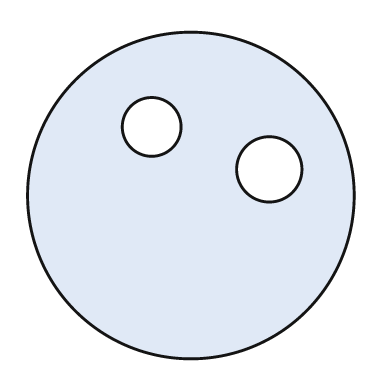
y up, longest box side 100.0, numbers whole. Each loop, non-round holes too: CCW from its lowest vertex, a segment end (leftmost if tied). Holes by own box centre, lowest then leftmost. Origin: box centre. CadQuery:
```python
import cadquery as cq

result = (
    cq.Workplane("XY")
    .moveTo(0.0, 0.0)
    .circle(50.0)
    .moveTo(24.0, 8.0)
    .circle(10.0)
    .moveTo(-12.0, 21.0)
    .circle(9.0)
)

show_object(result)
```